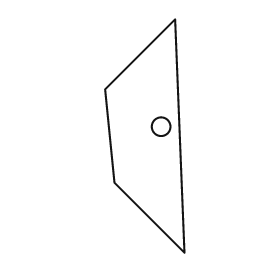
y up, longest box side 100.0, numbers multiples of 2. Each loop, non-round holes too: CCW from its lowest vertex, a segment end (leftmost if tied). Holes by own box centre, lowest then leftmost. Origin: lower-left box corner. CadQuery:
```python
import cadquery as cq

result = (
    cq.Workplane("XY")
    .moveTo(34.0, 0.0)
    .lineTo(30.0, 100.0)
    .lineTo(0.0, 70.0)
    .lineTo(4.0, 30.0)
    .close()
    .moveTo(24.0, 54.0)
    .circle(4.0)
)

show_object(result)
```